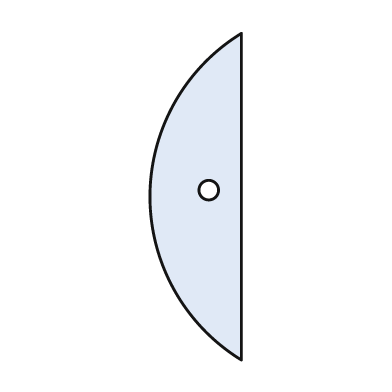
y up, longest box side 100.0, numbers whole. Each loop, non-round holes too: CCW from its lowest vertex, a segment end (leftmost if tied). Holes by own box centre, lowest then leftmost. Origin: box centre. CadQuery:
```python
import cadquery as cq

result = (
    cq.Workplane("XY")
    .moveTo(14.0, -50.0)
    .lineTo(14.0, 50.0)
    .threePointArc((-14.0, 0.0), (14.0, -50.0))
    .close()
    .moveTo(4.0, 2.0)
    .circle(3.0)
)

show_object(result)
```